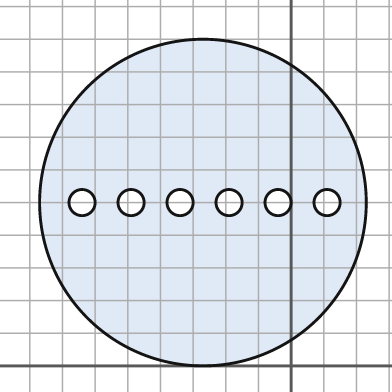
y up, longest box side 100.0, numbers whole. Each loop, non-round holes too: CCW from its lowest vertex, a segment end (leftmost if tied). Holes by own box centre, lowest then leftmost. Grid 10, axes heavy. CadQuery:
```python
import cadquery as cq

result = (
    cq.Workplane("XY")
    .moveTo(-27.0, 50.0)
    .circle(50.0)
    .moveTo(-64.0, 50.0)
    .circle(4.0)
    .moveTo(-49.0, 50.0)
    .circle(4.0)
    .moveTo(-34.0, 50.0)
    .circle(4.0)
    .moveTo(-19.0, 50.0)
    .circle(4.0)
    .moveTo(-4.0, 50.0)
    .circle(4.0)
    .moveTo(11.0, 50.0)
    .circle(4.0)
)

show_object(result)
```